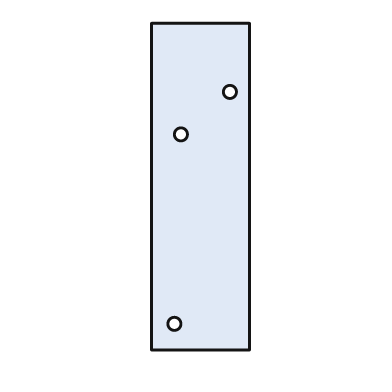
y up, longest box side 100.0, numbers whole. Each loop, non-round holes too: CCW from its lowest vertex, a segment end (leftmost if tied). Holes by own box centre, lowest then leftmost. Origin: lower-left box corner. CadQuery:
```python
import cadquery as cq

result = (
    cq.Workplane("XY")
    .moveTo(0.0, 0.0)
    .lineTo(30.0, 0.0)
    .lineTo(30.0, 100.0)
    .lineTo(0.0, 100.0)
    .close()
    .moveTo(7.0, 8.0)
    .circle(2.0)
    .moveTo(9.0, 66.0)
    .circle(2.0)
    .moveTo(24.0, 79.0)
    .circle(2.0)
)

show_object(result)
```